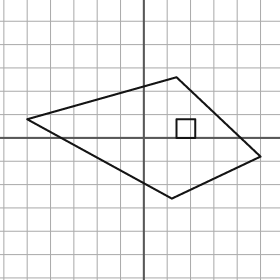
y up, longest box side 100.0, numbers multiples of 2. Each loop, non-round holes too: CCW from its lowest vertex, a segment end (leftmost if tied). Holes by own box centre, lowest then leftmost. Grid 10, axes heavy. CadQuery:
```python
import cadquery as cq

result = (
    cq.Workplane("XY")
    .moveTo(12.0, -26.0)
    .lineTo(50.0, -8.0)
    .lineTo(14.0, 26.0)
    .lineTo(-50.0, 8.0)
    .close()
    .moveTo(14.0, 0.0)
    .lineTo(22.0, 0.0)
    .lineTo(22.0, 8.0)
    .lineTo(14.0, 8.0)
    .close()
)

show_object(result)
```